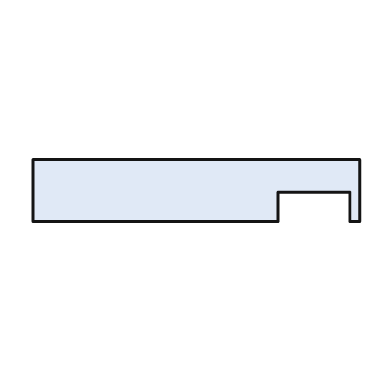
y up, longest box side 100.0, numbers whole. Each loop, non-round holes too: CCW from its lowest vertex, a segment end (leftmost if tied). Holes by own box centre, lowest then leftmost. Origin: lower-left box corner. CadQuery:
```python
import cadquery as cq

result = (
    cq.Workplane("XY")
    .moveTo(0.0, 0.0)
    .lineTo(75.0, 0.0)
    .lineTo(75.0, 9.0)
    .lineTo(97.0, 9.0)
    .lineTo(97.0, 0.0)
    .lineTo(100.0, 0.0)
    .lineTo(100.0, 19.0)
    .lineTo(0.0, 19.0)
    .close()
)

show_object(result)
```